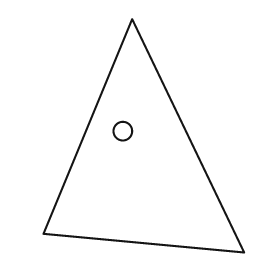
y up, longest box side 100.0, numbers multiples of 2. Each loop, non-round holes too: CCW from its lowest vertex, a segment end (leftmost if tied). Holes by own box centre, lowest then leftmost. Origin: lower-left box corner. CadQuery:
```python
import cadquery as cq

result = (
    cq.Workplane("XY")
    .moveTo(86.0, 0.0)
    .lineTo(38.0, 100.0)
    .lineTo(0.0, 8.0)
    .close()
    .moveTo(34.0, 52.0)
    .circle(4.0)
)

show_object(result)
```